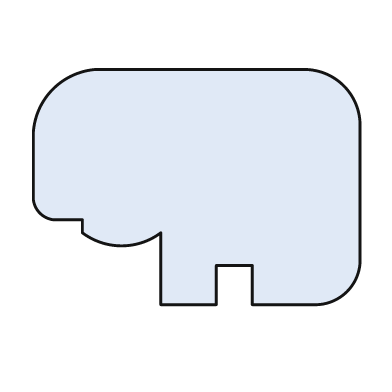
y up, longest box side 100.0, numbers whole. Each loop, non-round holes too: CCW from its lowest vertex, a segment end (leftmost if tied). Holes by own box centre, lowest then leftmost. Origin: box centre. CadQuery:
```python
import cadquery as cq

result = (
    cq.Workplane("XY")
    .moveTo(-11.0, -36.0)
    .lineTo(6.0, -36.0)
    .lineTo(6.0, -24.0)
    .lineTo(17.0, -24.0)
    .lineTo(17.0, -36.0)
    .lineTo(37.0, -36.0)
    .threePointArc((46.0, -32.0), (50.0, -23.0))
    .lineTo(50.0, 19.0)
    .threePointArc((45.0, 31.0), (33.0, 36.0))
    .lineTo(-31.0, 36.0)
    .threePointArc((-44.0, 30.0), (-50.0, 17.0))
    .lineTo(-50.0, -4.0)
    .threePointArc((-48.0, -8.0), (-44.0, -10.0))
    .lineTo(-35.0, -10.0)
    .lineTo(-35.0, -14.0)
    .threePointArc((-23.0, -18.0), (-11.0, -14.0))
    .close()
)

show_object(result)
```